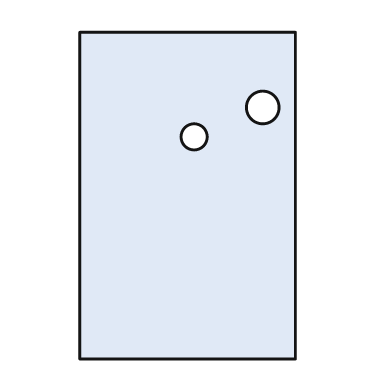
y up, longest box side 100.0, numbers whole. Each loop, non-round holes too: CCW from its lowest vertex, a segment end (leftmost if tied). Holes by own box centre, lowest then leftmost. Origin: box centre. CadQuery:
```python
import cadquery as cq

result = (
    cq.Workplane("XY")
    .moveTo(-33.0, -50.0)
    .lineTo(33.0, -50.0)
    .lineTo(33.0, 50.0)
    .lineTo(-33.0, 50.0)
    .close()
    .moveTo(2.0, 18.0)
    .circle(4.0)
    .moveTo(23.0, 27.0)
    .circle(5.0)
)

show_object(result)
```